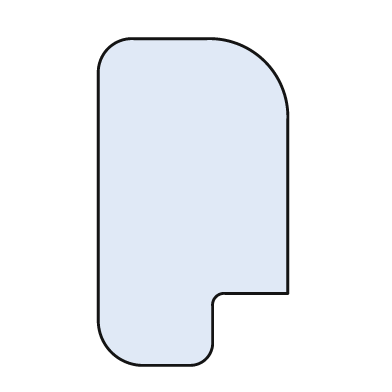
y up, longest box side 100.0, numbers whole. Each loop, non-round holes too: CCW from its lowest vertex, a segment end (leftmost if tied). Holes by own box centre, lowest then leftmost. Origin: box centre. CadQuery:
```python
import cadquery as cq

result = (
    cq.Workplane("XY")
    .moveTo(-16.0, -50.0)
    .lineTo(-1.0, -50.0)
    .threePointArc((4.0, -48.0), (6.0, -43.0))
    .lineTo(6.0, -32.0)
    .threePointArc((7.0, -29.0), (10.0, -28.0))
    .lineTo(29.0, -28.0)
    .lineTo(29.0, 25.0)
    .threePointArc((22.0, 43.0), (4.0, 50.0))
    .lineTo(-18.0, 50.0)
    .threePointArc((-26.0, 47.0), (-29.0, 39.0))
    .lineTo(-29.0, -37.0)
    .threePointArc((-25.0, -46.0), (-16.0, -50.0))
    .close()
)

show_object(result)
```